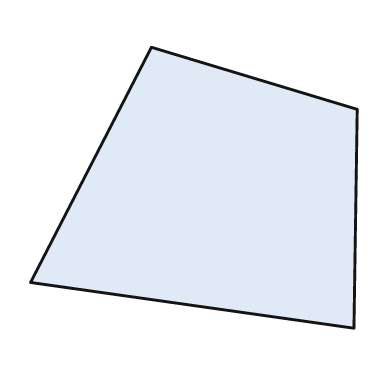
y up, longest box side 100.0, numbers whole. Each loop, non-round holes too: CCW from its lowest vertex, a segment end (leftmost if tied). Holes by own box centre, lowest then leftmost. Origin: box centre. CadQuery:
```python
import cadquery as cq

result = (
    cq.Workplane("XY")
    .moveTo(49.0, -43.0)
    .lineTo(50.0, 24.0)
    .lineTo(-13.0, 43.0)
    .lineTo(-50.0, -29.0)
    .close()
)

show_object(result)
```